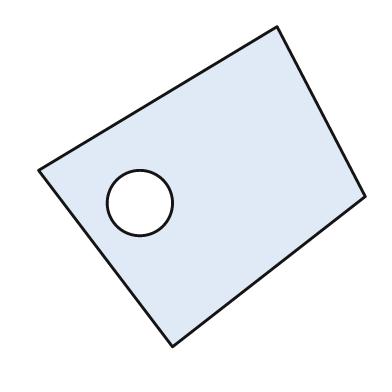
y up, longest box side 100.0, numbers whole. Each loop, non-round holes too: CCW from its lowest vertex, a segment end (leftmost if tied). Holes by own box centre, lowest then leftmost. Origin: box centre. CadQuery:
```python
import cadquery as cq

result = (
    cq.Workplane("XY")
    .moveTo(-9.0, -49.0)
    .lineTo(50.0, -3.0)
    .lineTo(23.0, 49.0)
    .lineTo(-50.0, 5.0)
    .close()
    .moveTo(-19.0, -5.0)
    .circle(10.0)
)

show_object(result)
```